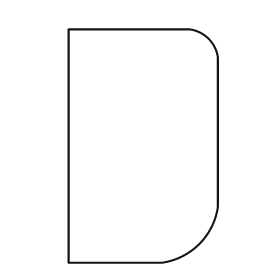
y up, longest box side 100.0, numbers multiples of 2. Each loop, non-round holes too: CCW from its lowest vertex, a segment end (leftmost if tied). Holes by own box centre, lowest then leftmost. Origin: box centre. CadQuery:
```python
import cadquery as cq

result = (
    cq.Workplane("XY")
    .moveTo(-32.0, -50.0)
    .lineTo(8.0, -50.0)
    .threePointArc((24.0, -42.0), (32.0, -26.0))
    .lineTo(32.0, 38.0)
    .threePointArc((28.0, 46.0), (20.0, 50.0))
    .lineTo(-32.0, 50.0)
    .close()
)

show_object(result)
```